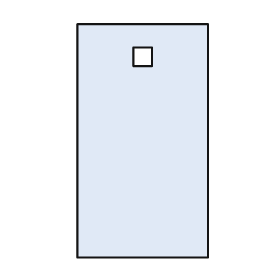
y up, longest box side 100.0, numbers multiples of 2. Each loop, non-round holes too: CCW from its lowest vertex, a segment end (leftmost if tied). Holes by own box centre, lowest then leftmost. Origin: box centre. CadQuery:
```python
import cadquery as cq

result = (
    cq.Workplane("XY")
    .moveTo(-28.0, -50.0)
    .lineTo(28.0, -50.0)
    .lineTo(28.0, 50.0)
    .lineTo(-28.0, 50.0)
    .close()
    .moveTo(-4.0, 32.0)
    .lineTo(4.0, 32.0)
    .lineTo(4.0, 40.0)
    .lineTo(-4.0, 40.0)
    .close()
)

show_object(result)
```